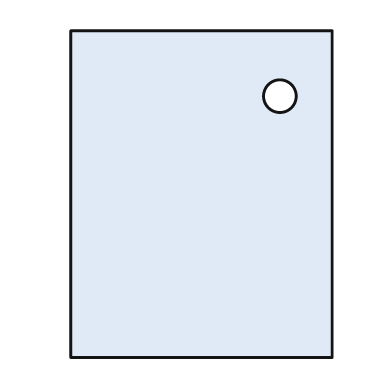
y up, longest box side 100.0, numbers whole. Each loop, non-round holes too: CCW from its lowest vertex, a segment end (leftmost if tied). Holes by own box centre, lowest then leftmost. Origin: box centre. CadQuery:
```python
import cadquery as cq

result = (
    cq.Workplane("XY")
    .moveTo(-40.0, -50.0)
    .lineTo(40.0, -50.0)
    .lineTo(40.0, 50.0)
    .lineTo(-40.0, 50.0)
    .close()
    .moveTo(24.0, 30.0)
    .circle(5.0)
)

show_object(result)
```